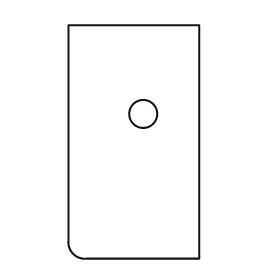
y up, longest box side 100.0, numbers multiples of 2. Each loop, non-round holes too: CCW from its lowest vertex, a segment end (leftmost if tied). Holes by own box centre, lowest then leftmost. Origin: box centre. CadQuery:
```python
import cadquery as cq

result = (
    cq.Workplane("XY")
    .moveTo(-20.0, -50.0)
    .lineTo(28.0, -50.0)
    .lineTo(28.0, 50.0)
    .lineTo(-28.0, 50.0)
    .lineTo(-28.0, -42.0)
    .threePointArc((-26.0, -48.0), (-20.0, -50.0))
    .close()
    .moveTo(4.0, 12.0)
    .circle(6.0)
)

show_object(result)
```